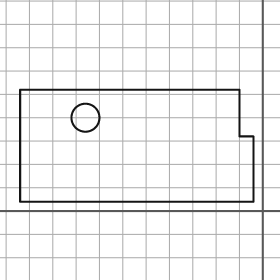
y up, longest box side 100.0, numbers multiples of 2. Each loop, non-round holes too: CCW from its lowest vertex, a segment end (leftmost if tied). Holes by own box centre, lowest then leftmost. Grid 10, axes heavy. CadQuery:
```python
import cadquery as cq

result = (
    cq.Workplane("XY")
    .moveTo(-104.0, 4.0)
    .lineTo(-4.0, 4.0)
    .lineTo(-4.0, 32.0)
    .lineTo(-10.0, 32.0)
    .lineTo(-10.0, 52.0)
    .lineTo(-104.0, 52.0)
    .close()
    .moveTo(-76.0, 40.0)
    .circle(6.0)
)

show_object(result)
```